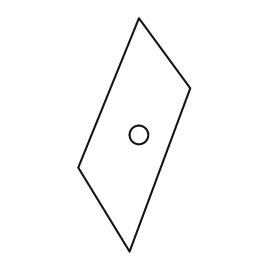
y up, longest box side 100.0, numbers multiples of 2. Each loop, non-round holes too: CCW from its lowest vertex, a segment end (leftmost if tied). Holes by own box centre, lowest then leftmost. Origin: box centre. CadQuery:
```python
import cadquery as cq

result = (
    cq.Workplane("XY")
    .moveTo(-2.0, -50.0)
    .lineTo(24.0, 20.0)
    .lineTo(2.0, 50.0)
    .lineTo(-24.0, -14.0)
    .close()
    .moveTo(2.0, 0.0)
    .circle(4.0)
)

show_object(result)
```